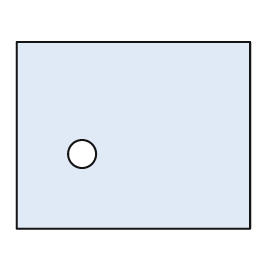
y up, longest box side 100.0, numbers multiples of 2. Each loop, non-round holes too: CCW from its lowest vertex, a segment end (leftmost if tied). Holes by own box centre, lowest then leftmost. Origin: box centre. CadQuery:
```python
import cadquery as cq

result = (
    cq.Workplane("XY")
    .moveTo(-50.0, -40.0)
    .lineTo(50.0, -40.0)
    .lineTo(50.0, 40.0)
    .lineTo(-50.0, 40.0)
    .close()
    .moveTo(-22.0, -8.0)
    .circle(6.0)
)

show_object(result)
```